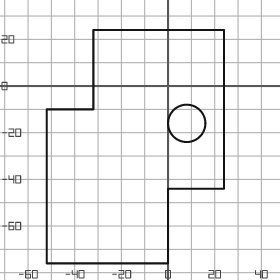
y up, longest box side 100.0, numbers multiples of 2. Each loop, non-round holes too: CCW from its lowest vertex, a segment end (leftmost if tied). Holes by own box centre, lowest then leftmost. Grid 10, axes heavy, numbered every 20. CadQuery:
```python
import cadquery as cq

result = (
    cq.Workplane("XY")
    .moveTo(-52.0, -76.0)
    .lineTo(0.0, -76.0)
    .lineTo(0.0, -44.0)
    .lineTo(24.0, -44.0)
    .lineTo(24.0, 24.0)
    .lineTo(-32.0, 24.0)
    .lineTo(-32.0, -10.0)
    .lineTo(-52.0, -10.0)
    .close()
    .moveTo(8.0, -16.0)
    .circle(8.0)
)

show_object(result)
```